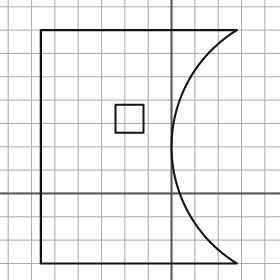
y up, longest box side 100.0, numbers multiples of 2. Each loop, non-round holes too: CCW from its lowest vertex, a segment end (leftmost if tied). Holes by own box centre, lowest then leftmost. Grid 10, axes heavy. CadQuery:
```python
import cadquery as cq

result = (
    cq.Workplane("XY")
    .moveTo(-56.0, -30.0)
    .lineTo(28.0, -30.0)
    .threePointArc((0.0, 20.0), (28.0, 70.0))
    .lineTo(-56.0, 70.0)
    .close()
    .moveTo(-24.0, 26.0)
    .lineTo(-12.0, 26.0)
    .lineTo(-12.0, 38.0)
    .lineTo(-24.0, 38.0)
    .close()
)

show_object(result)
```